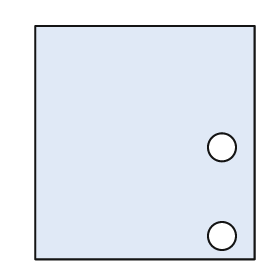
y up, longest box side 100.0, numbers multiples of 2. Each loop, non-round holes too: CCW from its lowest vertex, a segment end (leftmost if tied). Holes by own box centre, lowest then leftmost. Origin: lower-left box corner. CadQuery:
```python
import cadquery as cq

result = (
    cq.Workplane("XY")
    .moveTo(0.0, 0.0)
    .lineTo(94.0, 0.0)
    .lineTo(94.0, 100.0)
    .lineTo(0.0, 100.0)
    .close()
    .moveTo(80.0, 10.0)
    .circle(6.0)
    .moveTo(80.0, 48.0)
    .circle(6.0)
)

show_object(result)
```